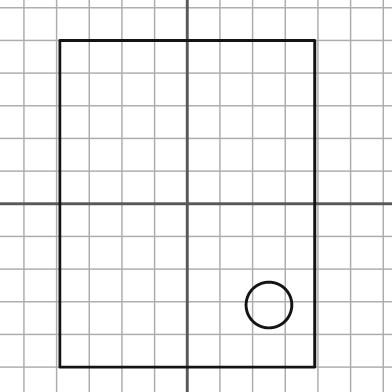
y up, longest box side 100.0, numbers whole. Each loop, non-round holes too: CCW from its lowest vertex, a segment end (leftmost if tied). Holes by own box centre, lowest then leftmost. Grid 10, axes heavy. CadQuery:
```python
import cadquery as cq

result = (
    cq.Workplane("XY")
    .moveTo(-39.0, -50.0)
    .lineTo(39.0, -50.0)
    .lineTo(39.0, 50.0)
    .lineTo(-39.0, 50.0)
    .close()
    .moveTo(25.0, -31.0)
    .circle(7.0)
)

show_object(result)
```